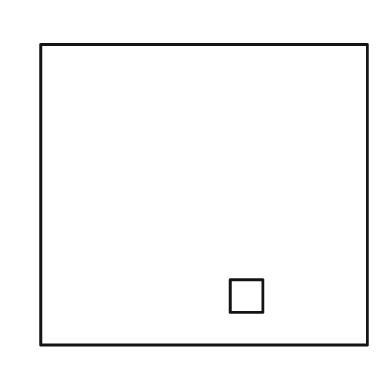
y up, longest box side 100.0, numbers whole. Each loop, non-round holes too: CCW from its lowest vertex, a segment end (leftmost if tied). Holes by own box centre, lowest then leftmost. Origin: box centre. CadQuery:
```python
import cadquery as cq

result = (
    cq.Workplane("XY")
    .moveTo(-50.0, -46.0)
    .lineTo(50.0, -46.0)
    .lineTo(50.0, 46.0)
    .lineTo(-50.0, 46.0)
    .close()
    .moveTo(8.0, -36.0)
    .lineTo(18.0, -36.0)
    .lineTo(18.0, -26.0)
    .lineTo(8.0, -26.0)
    .close()
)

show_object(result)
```